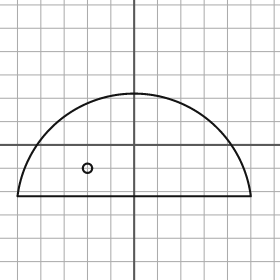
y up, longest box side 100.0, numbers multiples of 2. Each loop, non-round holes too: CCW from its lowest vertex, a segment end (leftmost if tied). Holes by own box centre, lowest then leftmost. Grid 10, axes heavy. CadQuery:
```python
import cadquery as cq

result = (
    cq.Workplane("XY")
    .moveTo(-50.0, -22.0)
    .lineTo(50.0, -22.0)
    .threePointArc((0.0, 22.0), (-50.0, -22.0))
    .close()
    .moveTo(-20.0, -10.0)
    .circle(2.0)
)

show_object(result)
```